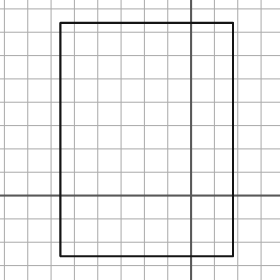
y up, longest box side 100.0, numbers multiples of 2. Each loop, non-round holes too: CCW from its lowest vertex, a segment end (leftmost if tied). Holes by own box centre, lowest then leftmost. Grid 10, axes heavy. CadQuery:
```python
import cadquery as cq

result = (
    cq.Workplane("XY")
    .moveTo(-56.0, -26.0)
    .lineTo(18.0, -26.0)
    .lineTo(18.0, 74.0)
    .lineTo(-56.0, 74.0)
    .close()
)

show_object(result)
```